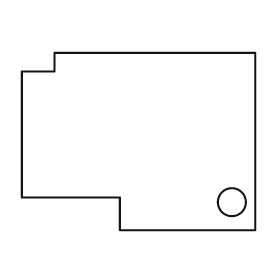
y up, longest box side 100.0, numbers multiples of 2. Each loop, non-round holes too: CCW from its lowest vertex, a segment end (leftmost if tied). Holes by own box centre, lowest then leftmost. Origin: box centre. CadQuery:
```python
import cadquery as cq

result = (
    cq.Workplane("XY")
    .moveTo(-8.0, -38.0)
    .lineTo(50.0, -38.0)
    .lineTo(50.0, 38.0)
    .lineTo(-36.0, 38.0)
    .lineTo(-36.0, 30.0)
    .lineTo(-50.0, 30.0)
    .lineTo(-50.0, -24.0)
    .lineTo(-8.0, -24.0)
    .close()
    .moveTo(40.0, -26.0)
    .circle(6.0)
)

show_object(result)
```